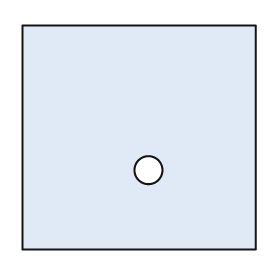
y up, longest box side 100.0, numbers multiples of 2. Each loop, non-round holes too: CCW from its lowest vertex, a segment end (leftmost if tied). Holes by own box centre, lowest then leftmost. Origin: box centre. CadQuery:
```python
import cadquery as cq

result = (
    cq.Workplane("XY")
    .moveTo(-50.0, -48.0)
    .lineTo(50.0, -48.0)
    .lineTo(50.0, 48.0)
    .lineTo(-50.0, 48.0)
    .close()
    .moveTo(4.0, -14.0)
    .circle(6.0)
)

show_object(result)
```